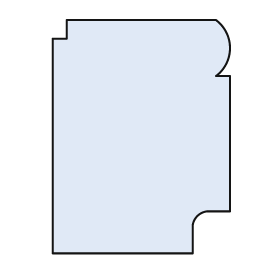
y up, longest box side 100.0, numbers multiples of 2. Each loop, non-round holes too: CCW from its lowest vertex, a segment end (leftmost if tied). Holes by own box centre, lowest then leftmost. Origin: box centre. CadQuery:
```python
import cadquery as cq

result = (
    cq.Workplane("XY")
    .moveTo(-38.0, -50.0)
    .lineTo(22.0, -50.0)
    .lineTo(22.0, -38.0)
    .threePointArc((24.0, -34.0), (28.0, -32.0))
    .lineTo(38.0, -32.0)
    .lineTo(38.0, 26.0)
    .lineTo(32.0, 26.0)
    .threePointArc((38.0, 38.0), (32.0, 50.0))
    .lineTo(-32.0, 50.0)
    .lineTo(-32.0, 42.0)
    .lineTo(-38.0, 42.0)
    .close()
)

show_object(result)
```